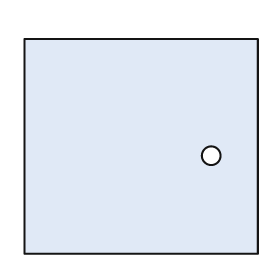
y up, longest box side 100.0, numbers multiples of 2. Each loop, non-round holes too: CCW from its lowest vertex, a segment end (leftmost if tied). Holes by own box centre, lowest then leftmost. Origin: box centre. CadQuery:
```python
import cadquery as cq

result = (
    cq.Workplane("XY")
    .moveTo(-50.0, -46.0)
    .lineTo(50.0, -46.0)
    .lineTo(50.0, 46.0)
    .lineTo(-50.0, 46.0)
    .close()
    .moveTo(30.0, -4.0)
    .circle(4.0)
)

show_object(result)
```